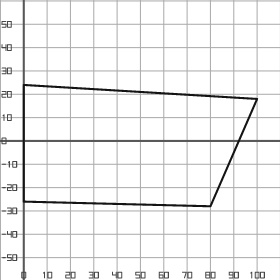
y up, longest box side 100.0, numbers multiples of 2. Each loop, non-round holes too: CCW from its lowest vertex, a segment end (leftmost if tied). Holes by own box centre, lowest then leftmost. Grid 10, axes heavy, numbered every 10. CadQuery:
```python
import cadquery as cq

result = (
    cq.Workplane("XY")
    .moveTo(80.0, -28.0)
    .lineTo(100.0, 18.0)
    .lineTo(0.0, 24.0)
    .lineTo(0.0, -26.0)
    .close()
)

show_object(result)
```